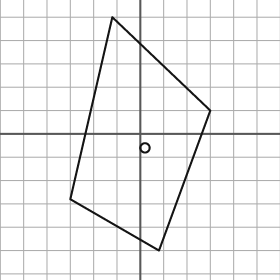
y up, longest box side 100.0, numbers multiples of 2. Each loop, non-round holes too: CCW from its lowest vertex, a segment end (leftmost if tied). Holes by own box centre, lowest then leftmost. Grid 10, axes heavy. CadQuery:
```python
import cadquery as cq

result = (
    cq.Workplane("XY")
    .moveTo(8.0, -50.0)
    .lineTo(30.0, 10.0)
    .lineTo(-12.0, 50.0)
    .lineTo(-30.0, -28.0)
    .close()
    .moveTo(2.0, -6.0)
    .circle(2.0)
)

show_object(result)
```